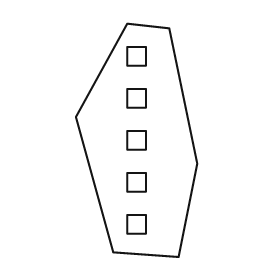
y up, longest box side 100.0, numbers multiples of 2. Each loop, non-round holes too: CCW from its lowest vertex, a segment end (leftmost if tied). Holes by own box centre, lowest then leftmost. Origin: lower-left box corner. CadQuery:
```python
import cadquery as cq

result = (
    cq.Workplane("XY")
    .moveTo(44.0, 0.0)
    .lineTo(52.0, 40.0)
    .lineTo(40.0, 98.0)
    .lineTo(22.0, 100.0)
    .lineTo(0.0, 60.0)
    .lineTo(16.0, 2.0)
    .close()
    .moveTo(22.0, 10.0)
    .lineTo(30.0, 10.0)
    .lineTo(30.0, 18.0)
    .lineTo(22.0, 18.0)
    .close()
    .moveTo(22.0, 28.0)
    .lineTo(30.0, 28.0)
    .lineTo(30.0, 36.0)
    .lineTo(22.0, 36.0)
    .close()
    .moveTo(22.0, 46.0)
    .lineTo(30.0, 46.0)
    .lineTo(30.0, 54.0)
    .lineTo(22.0, 54.0)
    .close()
    .moveTo(22.0, 64.0)
    .lineTo(30.0, 64.0)
    .lineTo(30.0, 72.0)
    .lineTo(22.0, 72.0)
    .close()
    .moveTo(22.0, 82.0)
    .lineTo(30.0, 82.0)
    .lineTo(30.0, 90.0)
    .lineTo(22.0, 90.0)
    .close()
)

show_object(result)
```